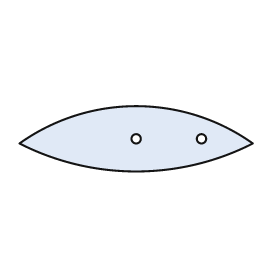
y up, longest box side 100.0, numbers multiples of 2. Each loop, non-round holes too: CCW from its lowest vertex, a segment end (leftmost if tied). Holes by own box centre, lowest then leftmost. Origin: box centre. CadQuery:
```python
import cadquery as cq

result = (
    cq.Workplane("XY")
    .moveTo(-50.0, -2.0)
    .threePointArc((0.0, -14.0), (50.0, -2.0))
    .threePointArc((0.0, 14.0), (-50.0, -2.0))
    .close()
    .moveTo(0.0, 0.0)
    .circle(2.0)
    .moveTo(28.0, 0.0)
    .circle(2.0)
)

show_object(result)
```